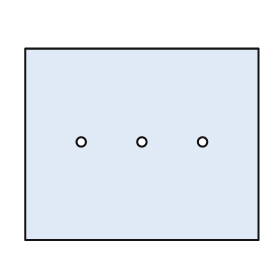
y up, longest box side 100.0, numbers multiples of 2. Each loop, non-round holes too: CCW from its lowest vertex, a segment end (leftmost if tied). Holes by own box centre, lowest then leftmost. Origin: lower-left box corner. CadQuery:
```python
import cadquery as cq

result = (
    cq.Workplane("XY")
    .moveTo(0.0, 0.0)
    .lineTo(100.0, 0.0)
    .lineTo(100.0, 82.0)
    .lineTo(0.0, 82.0)
    .close()
    .moveTo(24.0, 42.0)
    .circle(2.0)
    .moveTo(50.0, 42.0)
    .circle(2.0)
    .moveTo(76.0, 42.0)
    .circle(2.0)
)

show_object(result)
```